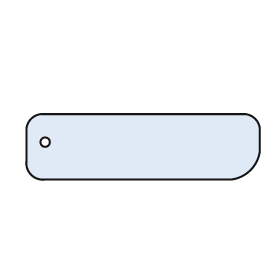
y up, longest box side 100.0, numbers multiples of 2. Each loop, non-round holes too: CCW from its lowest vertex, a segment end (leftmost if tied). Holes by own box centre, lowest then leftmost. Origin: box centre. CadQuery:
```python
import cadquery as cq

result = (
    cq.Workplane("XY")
    .moveTo(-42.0, -14.0)
    .lineTo(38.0, -14.0)
    .threePointArc((46.0, -10.0), (50.0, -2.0))
    .lineTo(50.0, 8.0)
    .threePointArc((48.0, 12.0), (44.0, 14.0))
    .lineTo(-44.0, 14.0)
    .threePointArc((-48.0, 12.0), (-50.0, 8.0))
    .lineTo(-50.0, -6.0)
    .threePointArc((-48.0, -12.0), (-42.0, -14.0))
    .close()
    .moveTo(-42.0, 2.0)
    .circle(2.0)
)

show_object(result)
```